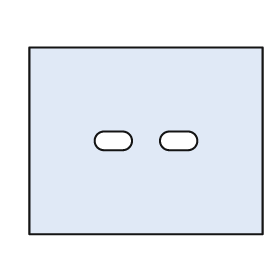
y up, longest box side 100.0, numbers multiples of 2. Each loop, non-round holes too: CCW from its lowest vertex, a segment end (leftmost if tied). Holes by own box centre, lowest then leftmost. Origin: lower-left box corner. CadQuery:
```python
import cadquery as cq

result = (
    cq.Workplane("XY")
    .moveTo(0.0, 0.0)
    .lineTo(100.0, 0.0)
    .lineTo(100.0, 80.0)
    .lineTo(0.0, 80.0)
    .close()
    .moveTo(32.0, 36.0)
    .lineTo(40.0, 36.0)
    .threePointArc((44.0, 40.0), (40.0, 44.0))
    .lineTo(32.0, 44.0)
    .threePointArc((28.0, 40.0), (32.0, 36.0))
    .close()
    .moveTo(60.0, 36.0)
    .lineTo(68.0, 36.0)
    .threePointArc((72.0, 40.0), (68.0, 44.0))
    .lineTo(60.0, 44.0)
    .threePointArc((56.0, 40.0), (60.0, 36.0))
    .close()
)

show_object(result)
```